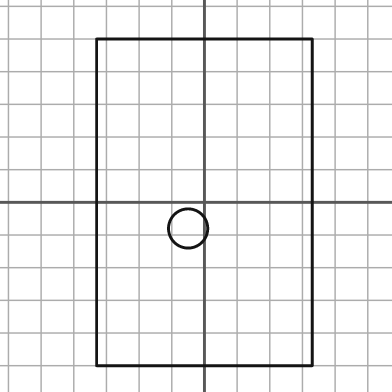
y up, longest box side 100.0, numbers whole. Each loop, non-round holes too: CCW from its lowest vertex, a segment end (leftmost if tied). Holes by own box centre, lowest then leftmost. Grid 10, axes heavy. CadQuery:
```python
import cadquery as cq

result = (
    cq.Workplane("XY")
    .moveTo(-33.0, -50.0)
    .lineTo(33.0, -50.0)
    .lineTo(33.0, 50.0)
    .lineTo(-33.0, 50.0)
    .close()
    .moveTo(-5.0, -8.0)
    .circle(6.0)
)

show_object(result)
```